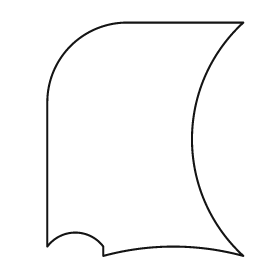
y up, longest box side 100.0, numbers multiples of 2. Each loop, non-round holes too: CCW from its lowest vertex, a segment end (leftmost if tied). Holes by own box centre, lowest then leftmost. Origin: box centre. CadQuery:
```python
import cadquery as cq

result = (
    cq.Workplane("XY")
    .moveTo(-18.0, -50.0)
    .threePointArc((12.0, -46.0), (42.0, -50.0))
    .threePointArc((20.0, 0.0), (42.0, 50.0))
    .lineTo(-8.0, 50.0)
    .threePointArc((-32.0, 40.0), (-42.0, 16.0))
    .lineTo(-42.0, -46.0)
    .threePointArc((-30.0, -40.0), (-18.0, -46.0))
    .close()
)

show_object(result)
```